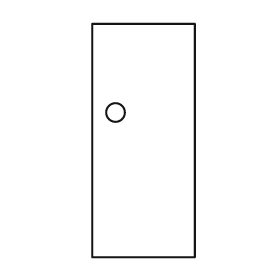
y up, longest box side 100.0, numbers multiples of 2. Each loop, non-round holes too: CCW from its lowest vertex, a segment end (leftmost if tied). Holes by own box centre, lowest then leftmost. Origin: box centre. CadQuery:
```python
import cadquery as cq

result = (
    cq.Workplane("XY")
    .moveTo(-22.0, -50.0)
    .lineTo(22.0, -50.0)
    .lineTo(22.0, 50.0)
    .lineTo(-22.0, 50.0)
    .close()
    .moveTo(-12.0, 12.0)
    .circle(4.0)
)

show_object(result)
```